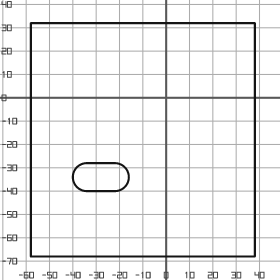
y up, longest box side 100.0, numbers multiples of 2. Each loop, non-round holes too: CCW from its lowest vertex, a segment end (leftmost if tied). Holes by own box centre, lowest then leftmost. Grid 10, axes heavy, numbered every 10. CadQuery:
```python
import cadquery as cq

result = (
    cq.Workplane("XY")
    .moveTo(-58.0, -68.0)
    .lineTo(38.0, -68.0)
    .lineTo(38.0, 32.0)
    .lineTo(-58.0, 32.0)
    .close()
    .moveTo(-34.0, -40.0)
    .lineTo(-22.0, -40.0)
    .threePointArc((-16.0, -34.0), (-22.0, -28.0))
    .lineTo(-34.0, -28.0)
    .threePointArc((-40.0, -34.0), (-34.0, -40.0))
    .close()
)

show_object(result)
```